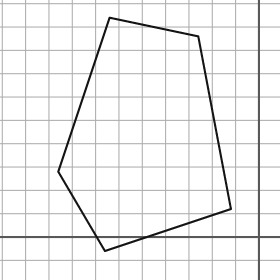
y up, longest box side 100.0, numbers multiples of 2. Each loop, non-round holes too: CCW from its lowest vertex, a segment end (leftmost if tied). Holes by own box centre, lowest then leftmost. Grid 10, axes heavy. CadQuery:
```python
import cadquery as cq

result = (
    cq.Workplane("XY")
    .moveTo(-66.0, -6.0)
    .lineTo(-12.0, 12.0)
    .lineTo(-26.0, 86.0)
    .lineTo(-64.0, 94.0)
    .lineTo(-86.0, 28.0)
    .close()
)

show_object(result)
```